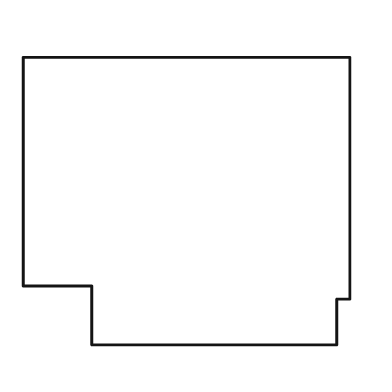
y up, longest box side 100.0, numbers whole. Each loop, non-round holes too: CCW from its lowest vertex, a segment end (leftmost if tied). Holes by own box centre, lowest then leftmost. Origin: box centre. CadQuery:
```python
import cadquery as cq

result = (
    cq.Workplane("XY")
    .moveTo(-29.0, -44.0)
    .lineTo(46.0, -44.0)
    .lineTo(46.0, -30.0)
    .lineTo(50.0, -30.0)
    .lineTo(50.0, 44.0)
    .lineTo(-50.0, 44.0)
    .lineTo(-50.0, -26.0)
    .lineTo(-29.0, -26.0)
    .close()
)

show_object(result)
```